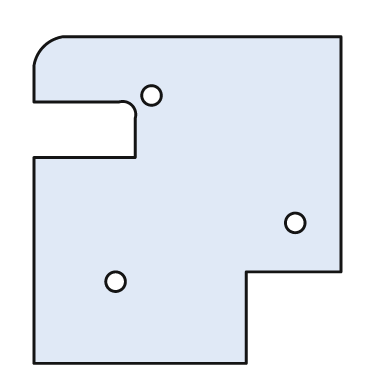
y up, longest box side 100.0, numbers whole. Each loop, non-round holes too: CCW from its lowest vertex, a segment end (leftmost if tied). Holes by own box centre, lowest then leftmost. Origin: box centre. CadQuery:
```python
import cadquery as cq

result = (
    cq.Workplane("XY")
    .moveTo(-47.0, -50.0)
    .lineTo(18.0, -50.0)
    .lineTo(18.0, -22.0)
    .lineTo(47.0, -22.0)
    .lineTo(47.0, 50.0)
    .lineTo(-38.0, 50.0)
    .threePointArc((-44.0, 47.0), (-47.0, 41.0))
    .lineTo(-47.0, 30.0)
    .lineTo(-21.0, 30.0)
    .threePointArc((-17.0, 29.0), (-16.0, 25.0))
    .lineTo(-16.0, 13.0)
    .lineTo(-47.0, 13.0)
    .close()
    .moveTo(-22.0, -25.0)
    .circle(3.0)
    .moveTo(33.0, -7.0)
    .circle(3.0)
    .moveTo(-11.0, 32.0)
    .circle(3.0)
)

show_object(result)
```